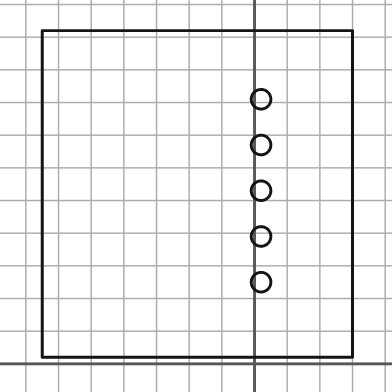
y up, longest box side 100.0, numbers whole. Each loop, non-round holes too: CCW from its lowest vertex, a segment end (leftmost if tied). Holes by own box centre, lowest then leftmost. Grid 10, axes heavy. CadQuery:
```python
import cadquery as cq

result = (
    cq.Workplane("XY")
    .moveTo(-65.0, 2.0)
    .lineTo(30.0, 2.0)
    .lineTo(30.0, 102.0)
    .lineTo(-65.0, 102.0)
    .close()
    .moveTo(2.0, 25.0)
    .circle(3.0)
    .moveTo(2.0, 39.0)
    .circle(3.0)
    .moveTo(2.0, 53.0)
    .circle(3.0)
    .moveTo(2.0, 67.0)
    .circle(3.0)
    .moveTo(2.0, 81.0)
    .circle(3.0)
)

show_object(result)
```